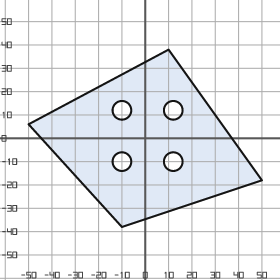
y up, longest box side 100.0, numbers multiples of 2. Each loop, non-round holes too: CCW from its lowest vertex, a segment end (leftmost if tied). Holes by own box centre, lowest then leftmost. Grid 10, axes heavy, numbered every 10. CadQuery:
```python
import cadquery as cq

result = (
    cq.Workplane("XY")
    .moveTo(-10.0, -38.0)
    .lineTo(50.0, -18.0)
    .lineTo(10.0, 38.0)
    .lineTo(-50.0, 6.0)
    .close()
    .moveTo(-10.0, -10.0)
    .circle(4.0)
    .moveTo(12.0, -10.0)
    .circle(4.0)
    .moveTo(-10.0, 12.0)
    .circle(4.0)
    .moveTo(12.0, 12.0)
    .circle(4.0)
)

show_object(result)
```